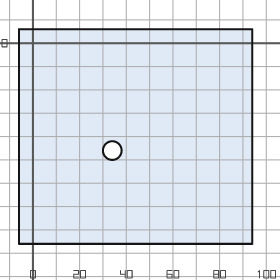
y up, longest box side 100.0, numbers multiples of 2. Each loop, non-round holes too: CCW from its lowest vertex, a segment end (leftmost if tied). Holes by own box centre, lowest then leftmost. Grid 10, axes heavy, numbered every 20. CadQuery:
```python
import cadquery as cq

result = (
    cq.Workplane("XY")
    .moveTo(-6.0, -86.0)
    .lineTo(94.0, -86.0)
    .lineTo(94.0, 6.0)
    .lineTo(-6.0, 6.0)
    .close()
    .moveTo(34.0, -46.0)
    .circle(4.0)
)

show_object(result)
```